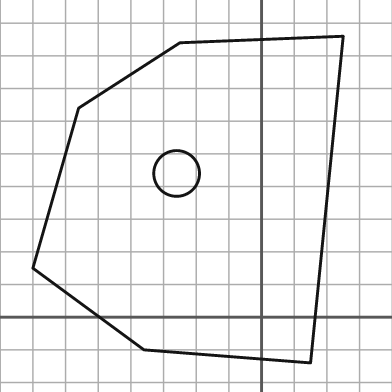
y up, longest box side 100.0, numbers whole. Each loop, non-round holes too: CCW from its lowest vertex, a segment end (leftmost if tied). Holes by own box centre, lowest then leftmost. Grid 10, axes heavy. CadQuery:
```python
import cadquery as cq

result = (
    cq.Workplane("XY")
    .moveTo(15.0, -14.0)
    .lineTo(25.0, 86.0)
    .lineTo(-25.0, 84.0)
    .lineTo(-56.0, 64.0)
    .lineTo(-70.0, 15.0)
    .lineTo(-36.0, -10.0)
    .close()
    .moveTo(-26.0, 44.0)
    .circle(7.0)
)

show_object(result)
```